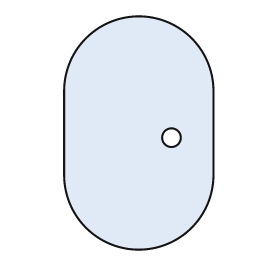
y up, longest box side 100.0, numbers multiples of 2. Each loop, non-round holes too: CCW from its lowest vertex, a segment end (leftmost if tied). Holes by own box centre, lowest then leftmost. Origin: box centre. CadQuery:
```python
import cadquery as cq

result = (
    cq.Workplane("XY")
    .moveTo(-32.0, -18.0)
    .threePointArc((0.0, -50.0), (32.0, -18.0))
    .lineTo(32.0, 18.0)
    .threePointArc((0.0, 50.0), (-32.0, 18.0))
    .close()
    .moveTo(14.0, -2.0)
    .circle(4.0)
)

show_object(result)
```